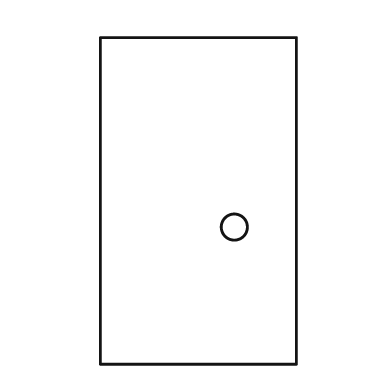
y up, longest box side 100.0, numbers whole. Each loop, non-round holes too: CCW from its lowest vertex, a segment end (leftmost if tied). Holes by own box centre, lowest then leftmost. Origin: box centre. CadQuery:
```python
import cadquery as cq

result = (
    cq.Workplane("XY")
    .moveTo(-30.0, -50.0)
    .lineTo(30.0, -50.0)
    .lineTo(30.0, 50.0)
    .lineTo(-30.0, 50.0)
    .close()
    .moveTo(11.0, -8.0)
    .circle(4.0)
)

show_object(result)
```